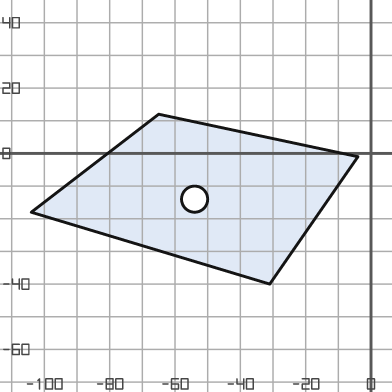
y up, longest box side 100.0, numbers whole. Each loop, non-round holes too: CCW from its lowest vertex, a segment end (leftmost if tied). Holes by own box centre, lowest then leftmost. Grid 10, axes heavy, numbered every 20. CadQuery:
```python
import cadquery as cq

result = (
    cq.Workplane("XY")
    .moveTo(-31.0, -40.0)
    .lineTo(-4.0, -1.0)
    .lineTo(-65.0, 12.0)
    .lineTo(-104.0, -18.0)
    .close()
    .moveTo(-54.0, -14.0)
    .circle(4.0)
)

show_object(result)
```